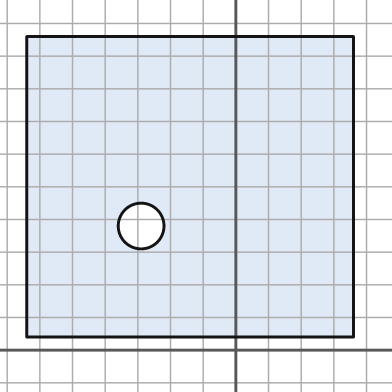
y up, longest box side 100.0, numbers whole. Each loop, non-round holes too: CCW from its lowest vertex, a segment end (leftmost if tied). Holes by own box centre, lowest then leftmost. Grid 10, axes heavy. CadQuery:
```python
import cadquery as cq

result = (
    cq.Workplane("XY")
    .moveTo(-64.0, 4.0)
    .lineTo(36.0, 4.0)
    .lineTo(36.0, 96.0)
    .lineTo(-64.0, 96.0)
    .close()
    .moveTo(-29.0, 38.0)
    .circle(7.0)
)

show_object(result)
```